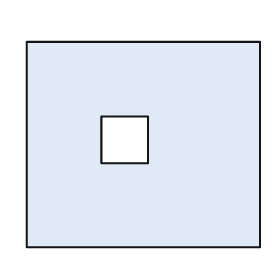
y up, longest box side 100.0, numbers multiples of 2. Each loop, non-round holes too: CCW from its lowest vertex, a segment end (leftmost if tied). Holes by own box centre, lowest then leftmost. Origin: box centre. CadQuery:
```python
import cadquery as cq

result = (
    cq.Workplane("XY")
    .moveTo(-50.0, -44.0)
    .lineTo(50.0, -44.0)
    .lineTo(50.0, 44.0)
    .lineTo(-50.0, 44.0)
    .close()
    .moveTo(-18.0, -8.0)
    .lineTo(2.0, -8.0)
    .lineTo(2.0, 12.0)
    .lineTo(-18.0, 12.0)
    .close()
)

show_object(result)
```